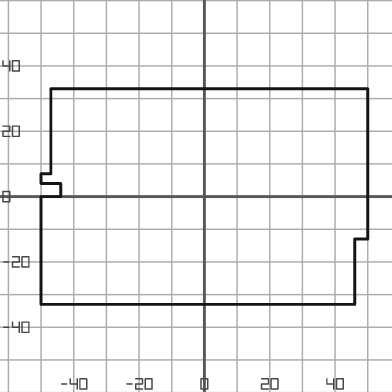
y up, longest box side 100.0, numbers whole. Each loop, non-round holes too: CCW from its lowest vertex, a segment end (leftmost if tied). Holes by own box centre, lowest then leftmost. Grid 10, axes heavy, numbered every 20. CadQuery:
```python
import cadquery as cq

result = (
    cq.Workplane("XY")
    .moveTo(-50.0, -33.0)
    .lineTo(46.0, -33.0)
    .lineTo(46.0, -13.0)
    .lineTo(50.0, -13.0)
    .lineTo(50.0, 33.0)
    .lineTo(-47.0, 33.0)
    .lineTo(-47.0, 7.0)
    .lineTo(-50.0, 7.0)
    .lineTo(-50.0, 4.0)
    .lineTo(-44.0, 4.0)
    .lineTo(-44.0, 0.0)
    .lineTo(-50.0, 0.0)
    .close()
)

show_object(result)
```